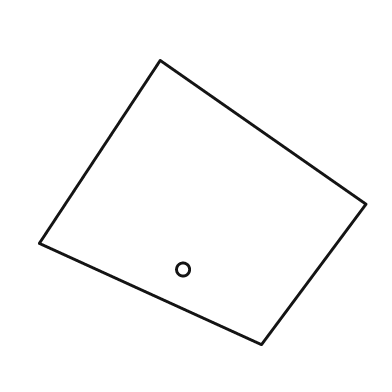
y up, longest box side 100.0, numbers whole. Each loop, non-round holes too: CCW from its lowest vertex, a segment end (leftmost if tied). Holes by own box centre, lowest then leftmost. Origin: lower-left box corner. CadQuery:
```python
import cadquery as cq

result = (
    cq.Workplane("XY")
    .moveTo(68.0, 0.0)
    .lineTo(100.0, 43.0)
    .lineTo(37.0, 87.0)
    .lineTo(0.0, 31.0)
    .close()
    .moveTo(44.0, 23.0)
    .circle(2.0)
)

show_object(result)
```